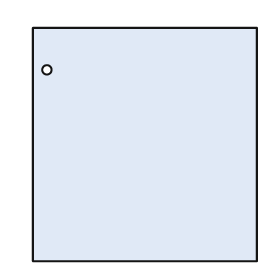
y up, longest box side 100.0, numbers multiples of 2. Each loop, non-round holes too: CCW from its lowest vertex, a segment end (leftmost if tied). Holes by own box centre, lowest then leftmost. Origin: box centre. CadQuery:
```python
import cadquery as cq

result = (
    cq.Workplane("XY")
    .moveTo(-48.0, -50.0)
    .lineTo(48.0, -50.0)
    .lineTo(48.0, 50.0)
    .lineTo(-48.0, 50.0)
    .close()
    .moveTo(-42.0, 32.0)
    .circle(2.0)
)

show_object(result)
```